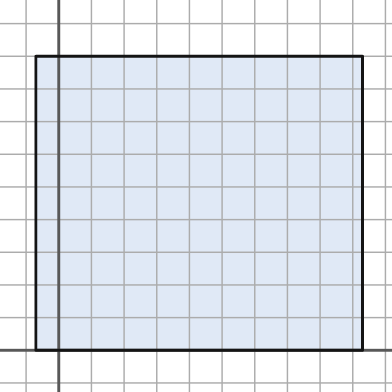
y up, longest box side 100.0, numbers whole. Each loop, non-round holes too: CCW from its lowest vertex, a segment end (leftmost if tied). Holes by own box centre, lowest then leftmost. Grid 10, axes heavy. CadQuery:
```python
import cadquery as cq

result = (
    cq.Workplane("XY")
    .moveTo(-7.0, 0.0)
    .lineTo(93.0, 0.0)
    .lineTo(93.0, 90.0)
    .lineTo(-7.0, 90.0)
    .close()
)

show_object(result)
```